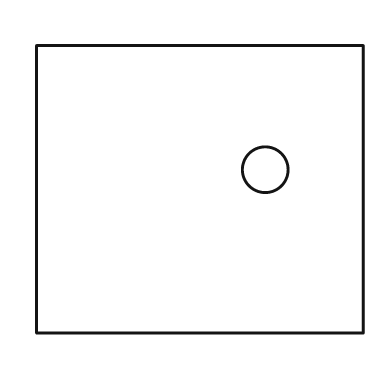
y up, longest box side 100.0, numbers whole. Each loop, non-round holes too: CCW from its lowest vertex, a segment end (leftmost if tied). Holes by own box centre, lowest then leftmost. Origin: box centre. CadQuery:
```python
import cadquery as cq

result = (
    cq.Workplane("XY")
    .moveTo(-50.0, -44.0)
    .lineTo(50.0, -44.0)
    .lineTo(50.0, 44.0)
    .lineTo(-50.0, 44.0)
    .close()
    .moveTo(20.0, 6.0)
    .circle(7.0)
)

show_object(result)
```